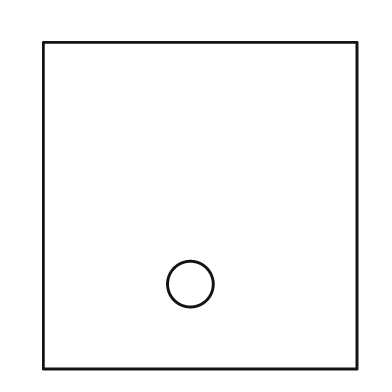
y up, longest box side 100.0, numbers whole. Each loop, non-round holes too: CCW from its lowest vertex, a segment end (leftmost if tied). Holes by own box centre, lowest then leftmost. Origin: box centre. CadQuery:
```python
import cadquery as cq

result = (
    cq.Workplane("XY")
    .moveTo(-48.0, -50.0)
    .lineTo(48.0, -50.0)
    .lineTo(48.0, 50.0)
    .lineTo(-48.0, 50.0)
    .close()
    .moveTo(-3.0, -24.0)
    .circle(7.0)
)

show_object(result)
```